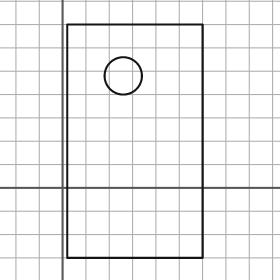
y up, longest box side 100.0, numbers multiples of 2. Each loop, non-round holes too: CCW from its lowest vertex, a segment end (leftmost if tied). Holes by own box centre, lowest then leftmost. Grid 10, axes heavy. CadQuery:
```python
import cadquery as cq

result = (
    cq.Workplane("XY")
    .moveTo(2.0, -30.0)
    .lineTo(60.0, -30.0)
    .lineTo(60.0, 70.0)
    .lineTo(2.0, 70.0)
    .close()
    .moveTo(26.0, 48.0)
    .circle(8.0)
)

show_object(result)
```